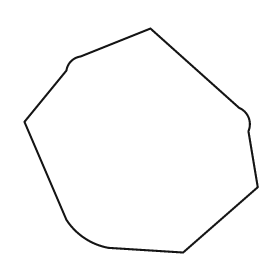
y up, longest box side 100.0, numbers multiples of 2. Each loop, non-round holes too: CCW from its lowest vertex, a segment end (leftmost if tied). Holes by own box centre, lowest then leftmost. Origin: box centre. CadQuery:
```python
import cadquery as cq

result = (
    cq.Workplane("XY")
    .moveTo(18.0, -48.0)
    .lineTo(50.0, -20.0)
    .lineTo(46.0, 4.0)
    .threePointArc((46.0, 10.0), (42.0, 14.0))
    .lineTo(4.0, 48.0)
    .lineTo(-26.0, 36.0)
    .threePointArc((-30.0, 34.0), (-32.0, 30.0))
    .lineTo(-50.0, 8.0)
    .lineTo(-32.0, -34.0)
    .threePointArc((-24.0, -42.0), (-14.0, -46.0))
    .close()
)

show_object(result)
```